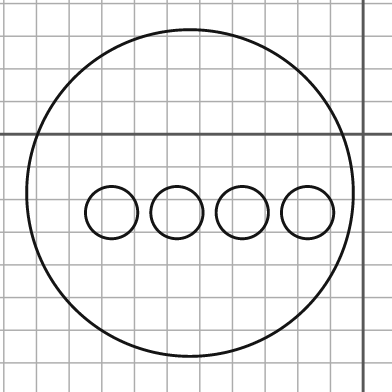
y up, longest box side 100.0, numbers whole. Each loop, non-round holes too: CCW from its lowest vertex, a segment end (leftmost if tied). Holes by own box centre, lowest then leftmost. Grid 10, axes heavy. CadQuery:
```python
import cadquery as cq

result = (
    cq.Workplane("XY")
    .moveTo(-53.0, -18.0)
    .circle(50.0)
    .moveTo(-77.0, -24.0)
    .circle(8.0)
    .moveTo(-57.0, -24.0)
    .circle(8.0)
    .moveTo(-37.0, -24.0)
    .circle(8.0)
    .moveTo(-17.0, -24.0)
    .circle(8.0)
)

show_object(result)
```